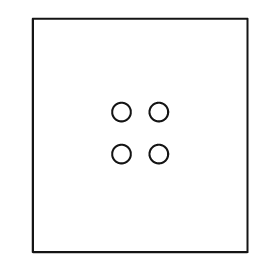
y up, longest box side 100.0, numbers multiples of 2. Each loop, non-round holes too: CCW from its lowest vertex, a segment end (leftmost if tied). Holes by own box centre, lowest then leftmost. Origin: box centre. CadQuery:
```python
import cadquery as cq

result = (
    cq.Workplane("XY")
    .moveTo(-46.0, -50.0)
    .lineTo(46.0, -50.0)
    .lineTo(46.0, 50.0)
    .lineTo(-46.0, 50.0)
    .close()
    .moveTo(-8.0, -8.0)
    .circle(4.0)
    .moveTo(8.0, -8.0)
    .circle(4.0)
    .moveTo(-8.0, 10.0)
    .circle(4.0)
    .moveTo(8.0, 10.0)
    .circle(4.0)
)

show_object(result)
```